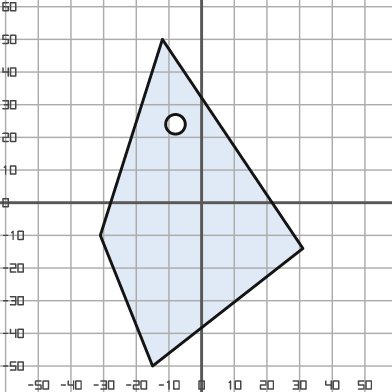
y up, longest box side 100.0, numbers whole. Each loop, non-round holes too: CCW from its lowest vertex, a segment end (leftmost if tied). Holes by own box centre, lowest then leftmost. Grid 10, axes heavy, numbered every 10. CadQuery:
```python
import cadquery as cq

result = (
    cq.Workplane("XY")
    .moveTo(-15.0, -50.0)
    .lineTo(31.0, -14.0)
    .lineTo(-12.0, 50.0)
    .lineTo(-31.0, -10.0)
    .close()
    .moveTo(-8.0, 24.0)
    .circle(3.0)
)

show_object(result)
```